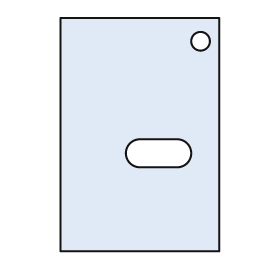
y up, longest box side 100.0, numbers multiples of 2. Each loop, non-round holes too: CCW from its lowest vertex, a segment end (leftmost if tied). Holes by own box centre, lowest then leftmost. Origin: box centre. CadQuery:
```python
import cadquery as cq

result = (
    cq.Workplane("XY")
    .moveTo(-34.0, -50.0)
    .lineTo(34.0, -50.0)
    .lineTo(34.0, 50.0)
    .lineTo(-34.0, 50.0)
    .close()
    .moveTo(0.0, -14.0)
    .lineTo(16.0, -14.0)
    .threePointArc((22.0, -8.0), (16.0, -2.0))
    .lineTo(0.0, -2.0)
    .threePointArc((-6.0, -8.0), (0.0, -14.0))
    .close()
    .moveTo(26.0, 40.0)
    .circle(4.0)
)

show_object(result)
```